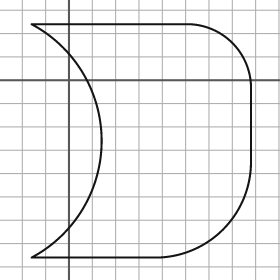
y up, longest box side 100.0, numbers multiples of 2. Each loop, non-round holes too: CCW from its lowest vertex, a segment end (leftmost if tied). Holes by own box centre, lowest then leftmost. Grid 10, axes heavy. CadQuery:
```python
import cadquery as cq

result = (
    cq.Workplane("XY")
    .moveTo(-16.0, -76.0)
    .lineTo(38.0, -76.0)
    .threePointArc((66.0, -64.0), (78.0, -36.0))
    .lineTo(78.0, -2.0)
    .threePointArc((70.0, 16.0), (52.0, 24.0))
    .lineTo(-16.0, 24.0)
    .threePointArc((14.0, -26.0), (-16.0, -76.0))
    .close()
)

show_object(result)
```